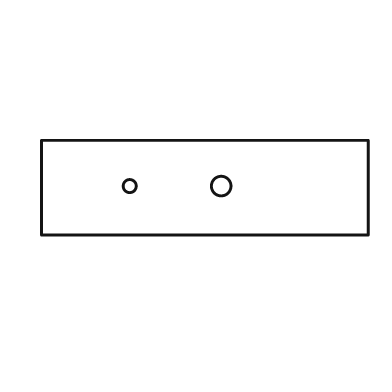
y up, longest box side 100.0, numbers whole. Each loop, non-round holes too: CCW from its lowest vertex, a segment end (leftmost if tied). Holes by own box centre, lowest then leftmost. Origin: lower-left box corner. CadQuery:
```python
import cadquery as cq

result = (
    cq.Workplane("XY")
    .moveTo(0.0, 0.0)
    .lineTo(100.0, 0.0)
    .lineTo(100.0, 29.0)
    .lineTo(0.0, 29.0)
    .close()
    .moveTo(27.0, 15.0)
    .circle(2.0)
    .moveTo(55.0, 15.0)
    .circle(3.0)
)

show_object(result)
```